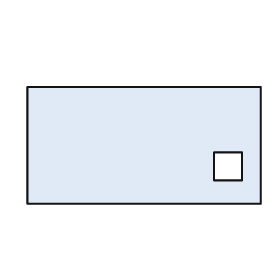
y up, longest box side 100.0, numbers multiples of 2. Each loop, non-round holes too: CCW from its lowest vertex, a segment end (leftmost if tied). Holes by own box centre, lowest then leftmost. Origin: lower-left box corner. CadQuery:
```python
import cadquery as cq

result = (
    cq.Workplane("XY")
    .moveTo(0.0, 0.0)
    .lineTo(100.0, 0.0)
    .lineTo(100.0, 50.0)
    .lineTo(0.0, 50.0)
    .close()
    .moveTo(80.0, 10.0)
    .lineTo(92.0, 10.0)
    .lineTo(92.0, 22.0)
    .lineTo(80.0, 22.0)
    .close()
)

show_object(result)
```